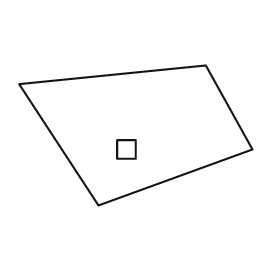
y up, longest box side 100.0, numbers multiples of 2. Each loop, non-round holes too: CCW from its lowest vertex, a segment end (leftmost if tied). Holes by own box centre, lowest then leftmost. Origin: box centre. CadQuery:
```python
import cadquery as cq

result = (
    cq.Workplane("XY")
    .moveTo(-16.0, -30.0)
    .lineTo(50.0, -6.0)
    .lineTo(30.0, 30.0)
    .lineTo(-50.0, 22.0)
    .close()
    .moveTo(-8.0, -10.0)
    .lineTo(0.0, -10.0)
    .lineTo(0.0, -2.0)
    .lineTo(-8.0, -2.0)
    .close()
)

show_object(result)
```